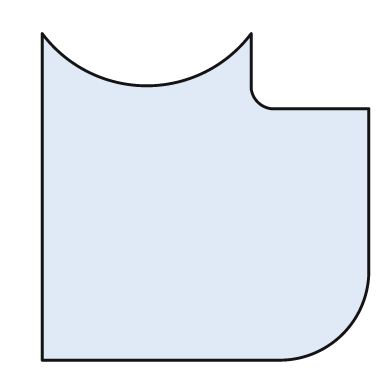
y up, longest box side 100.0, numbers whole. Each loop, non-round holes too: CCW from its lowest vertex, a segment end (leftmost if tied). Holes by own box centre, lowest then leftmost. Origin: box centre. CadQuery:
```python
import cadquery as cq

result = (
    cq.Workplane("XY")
    .moveTo(-50.0, -50.0)
    .lineTo(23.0, -50.0)
    .threePointArc((42.0, -42.0), (50.0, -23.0))
    .lineTo(50.0, 27.0)
    .lineTo(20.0, 27.0)
    .threePointArc((16.0, 29.0), (14.0, 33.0))
    .lineTo(14.0, 50.0)
    .threePointArc((-18.0, 34.0), (-50.0, 50.0))
    .close()
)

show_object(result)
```